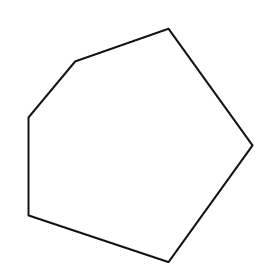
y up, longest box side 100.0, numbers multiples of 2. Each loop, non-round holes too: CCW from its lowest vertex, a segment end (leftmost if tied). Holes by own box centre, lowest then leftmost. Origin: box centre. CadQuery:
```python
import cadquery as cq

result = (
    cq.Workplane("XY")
    .moveTo(12.0, -50.0)
    .lineTo(48.0, 0.0)
    .lineTo(12.0, 50.0)
    .lineTo(-28.0, 36.0)
    .lineTo(-48.0, 12.0)
    .lineTo(-48.0, -30.0)
    .close()
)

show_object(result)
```